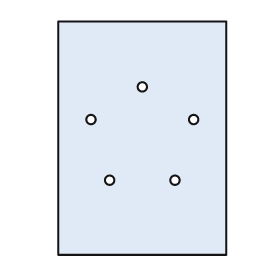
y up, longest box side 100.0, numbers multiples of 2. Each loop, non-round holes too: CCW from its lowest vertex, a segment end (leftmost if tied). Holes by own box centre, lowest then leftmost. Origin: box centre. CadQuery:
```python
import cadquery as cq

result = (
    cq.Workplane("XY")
    .moveTo(-36.0, -50.0)
    .lineTo(36.0, -50.0)
    .lineTo(36.0, 50.0)
    .lineTo(-36.0, 50.0)
    .close()
    .moveTo(-14.0, -18.0)
    .circle(2.0)
    .moveTo(14.0, -18.0)
    .circle(2.0)
    .moveTo(-22.0, 8.0)
    .circle(2.0)
    .moveTo(22.0, 8.0)
    .circle(2.0)
    .moveTo(0.0, 22.0)
    .circle(2.0)
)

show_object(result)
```